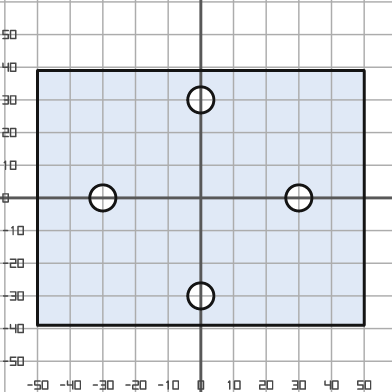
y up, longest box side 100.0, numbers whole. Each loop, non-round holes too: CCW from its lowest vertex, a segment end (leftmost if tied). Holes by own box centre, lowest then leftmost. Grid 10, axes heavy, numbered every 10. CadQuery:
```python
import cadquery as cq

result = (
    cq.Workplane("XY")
    .moveTo(-50.0, -39.0)
    .lineTo(50.0, -39.0)
    .lineTo(50.0, 39.0)
    .lineTo(-50.0, 39.0)
    .close()
    .moveTo(0.0, -30.0)
    .circle(4.0)
    .moveTo(-30.0, 0.0)
    .circle(4.0)
    .moveTo(30.0, 0.0)
    .circle(4.0)
    .moveTo(0.0, 30.0)
    .circle(4.0)
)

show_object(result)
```